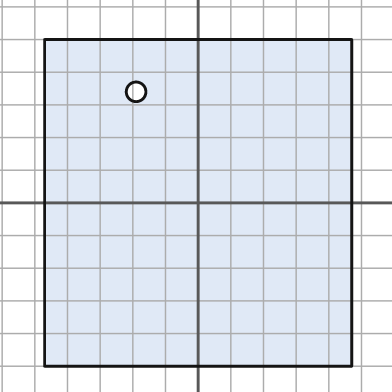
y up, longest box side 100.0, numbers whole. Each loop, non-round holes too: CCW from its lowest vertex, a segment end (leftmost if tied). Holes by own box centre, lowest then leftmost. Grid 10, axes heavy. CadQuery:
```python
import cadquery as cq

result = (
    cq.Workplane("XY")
    .moveTo(-47.0, -50.0)
    .lineTo(47.0, -50.0)
    .lineTo(47.0, 50.0)
    .lineTo(-47.0, 50.0)
    .close()
    .moveTo(-19.0, 34.0)
    .circle(3.0)
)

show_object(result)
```